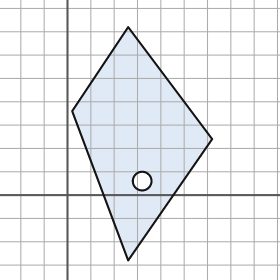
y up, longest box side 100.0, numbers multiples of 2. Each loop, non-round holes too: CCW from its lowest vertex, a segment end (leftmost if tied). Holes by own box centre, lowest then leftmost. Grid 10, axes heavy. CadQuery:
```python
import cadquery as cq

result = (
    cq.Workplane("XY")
    .moveTo(26.0, -28.0)
    .lineTo(62.0, 24.0)
    .lineTo(26.0, 72.0)
    .lineTo(2.0, 36.0)
    .close()
    .moveTo(32.0, 6.0)
    .circle(4.0)
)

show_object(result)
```